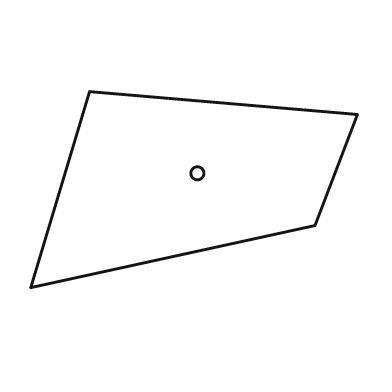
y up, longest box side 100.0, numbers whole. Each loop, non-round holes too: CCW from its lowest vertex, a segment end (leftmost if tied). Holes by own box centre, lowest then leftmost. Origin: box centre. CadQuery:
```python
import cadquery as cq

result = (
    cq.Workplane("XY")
    .moveTo(-50.0, -30.0)
    .lineTo(37.0, -11.0)
    .lineTo(50.0, 23.0)
    .lineTo(-32.0, 30.0)
    .close()
    .moveTo(1.0, 5.0)
    .circle(2.0)
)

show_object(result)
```